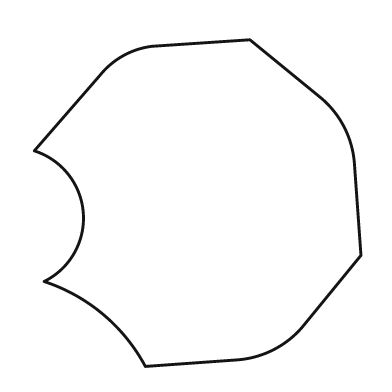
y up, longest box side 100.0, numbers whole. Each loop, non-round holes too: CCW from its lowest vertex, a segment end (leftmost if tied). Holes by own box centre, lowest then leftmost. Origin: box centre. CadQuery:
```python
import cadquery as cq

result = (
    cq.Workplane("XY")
    .moveTo(-16.0, -50.0)
    .lineTo(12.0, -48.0)
    .threePointArc((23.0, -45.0), (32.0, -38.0))
    .lineTo(50.0, -16.0)
    .lineTo(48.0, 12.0)
    .threePointArc((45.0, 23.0), (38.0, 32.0))
    .lineTo(16.0, 50.0)
    .lineTo(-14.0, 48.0)
    .threePointArc((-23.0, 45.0), (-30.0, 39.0))
    .lineTo(-50.0, 16.0)
    .threePointArc((-35.0, -3.0), (-47.0, -24.0))
    .threePointArc((-29.0, -34.0), (-16.0, -50.0))
    .close()
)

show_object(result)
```